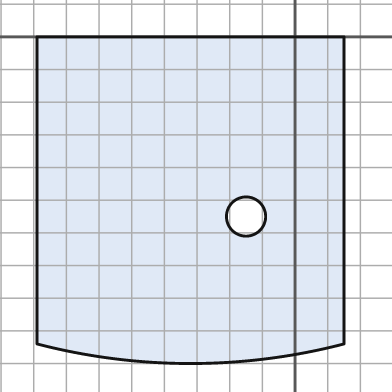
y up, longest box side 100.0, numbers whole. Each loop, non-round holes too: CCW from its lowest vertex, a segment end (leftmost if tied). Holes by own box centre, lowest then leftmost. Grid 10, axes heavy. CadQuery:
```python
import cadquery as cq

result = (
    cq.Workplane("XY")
    .moveTo(-79.0, -94.0)
    .threePointArc((-32.0, -100.0), (15.0, -94.0))
    .lineTo(15.0, 0.0)
    .lineTo(-79.0, 0.0)
    .close()
    .moveTo(-15.0, -55.0)
    .circle(6.0)
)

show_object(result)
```